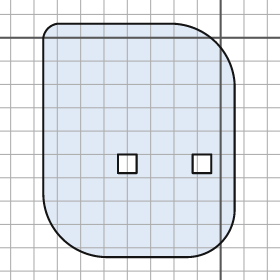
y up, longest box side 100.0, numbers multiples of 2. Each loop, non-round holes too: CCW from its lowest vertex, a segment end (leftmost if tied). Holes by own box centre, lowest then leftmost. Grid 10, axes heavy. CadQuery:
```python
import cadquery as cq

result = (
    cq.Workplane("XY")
    .moveTo(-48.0, -94.0)
    .lineTo(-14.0, -94.0)
    .threePointArc((0.0, -88.0), (6.0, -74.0))
    .lineTo(6.0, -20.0)
    .threePointArc((-2.0, -2.0), (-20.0, 6.0))
    .lineTo(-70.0, 6.0)
    .threePointArc((-74.0, 4.0), (-76.0, 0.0))
    .lineTo(-76.0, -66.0)
    .threePointArc((-68.0, -86.0), (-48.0, -94.0))
    .close()
    .moveTo(-44.0, -58.0)
    .lineTo(-36.0, -58.0)
    .lineTo(-36.0, -50.0)
    .lineTo(-44.0, -50.0)
    .close()
    .moveTo(-12.0, -58.0)
    .lineTo(-4.0, -58.0)
    .lineTo(-4.0, -50.0)
    .lineTo(-12.0, -50.0)
    .close()
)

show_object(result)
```